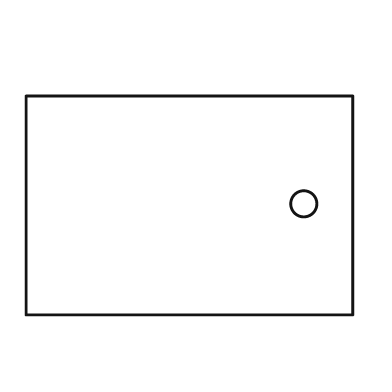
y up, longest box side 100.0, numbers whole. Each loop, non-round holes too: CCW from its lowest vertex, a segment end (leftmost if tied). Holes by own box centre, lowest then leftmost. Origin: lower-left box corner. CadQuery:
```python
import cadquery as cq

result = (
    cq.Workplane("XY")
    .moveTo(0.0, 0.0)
    .lineTo(100.0, 0.0)
    .lineTo(100.0, 67.0)
    .lineTo(0.0, 67.0)
    .close()
    .moveTo(85.0, 34.0)
    .circle(4.0)
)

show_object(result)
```